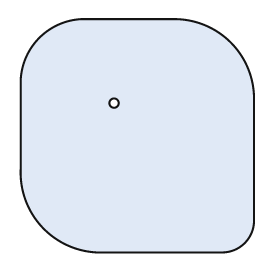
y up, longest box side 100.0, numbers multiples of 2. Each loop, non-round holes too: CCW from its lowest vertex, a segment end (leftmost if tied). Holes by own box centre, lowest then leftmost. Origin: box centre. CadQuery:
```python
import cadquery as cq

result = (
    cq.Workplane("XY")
    .moveTo(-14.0, -50.0)
    .lineTo(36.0, -50.0)
    .threePointArc((46.0, -46.0), (50.0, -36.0))
    .lineTo(50.0, 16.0)
    .threePointArc((40.0, 40.0), (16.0, 50.0))
    .lineTo(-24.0, 50.0)
    .threePointArc((-42.0, 42.0), (-50.0, 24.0))
    .lineTo(-50.0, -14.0)
    .threePointArc((-40.0, -40.0), (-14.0, -50.0))
    .close()
    .moveTo(-10.0, 14.0)
    .circle(2.0)
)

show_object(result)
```